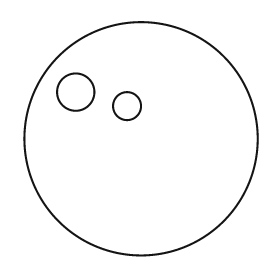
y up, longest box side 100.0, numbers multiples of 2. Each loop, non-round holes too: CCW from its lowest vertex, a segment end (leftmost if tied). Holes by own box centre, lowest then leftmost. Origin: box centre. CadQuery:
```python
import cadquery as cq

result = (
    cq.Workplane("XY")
    .moveTo(0.0, 0.0)
    .circle(50.0)
    .moveTo(-6.0, 14.0)
    .circle(6.0)
    .moveTo(-28.0, 20.0)
    .circle(8.0)
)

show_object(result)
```